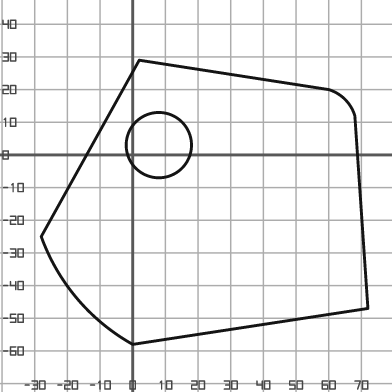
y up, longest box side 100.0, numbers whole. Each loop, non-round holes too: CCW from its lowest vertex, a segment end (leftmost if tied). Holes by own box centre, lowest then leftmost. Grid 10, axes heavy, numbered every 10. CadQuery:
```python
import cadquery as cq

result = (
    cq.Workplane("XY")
    .moveTo(0.0, -58.0)
    .lineTo(72.0, -47.0)
    .lineTo(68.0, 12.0)
    .threePointArc((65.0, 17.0), (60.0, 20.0))
    .lineTo(2.0, 29.0)
    .lineTo(-28.0, -25.0)
    .threePointArc((-17.0, -44.0), (0.0, -58.0))
    .close()
    .moveTo(8.0, 3.0)
    .circle(10.0)
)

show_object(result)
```